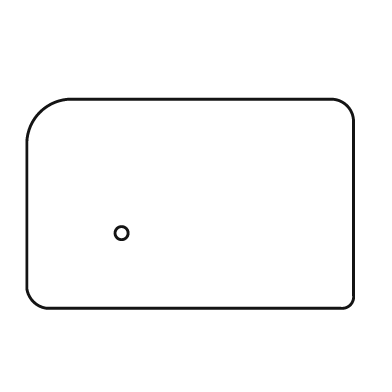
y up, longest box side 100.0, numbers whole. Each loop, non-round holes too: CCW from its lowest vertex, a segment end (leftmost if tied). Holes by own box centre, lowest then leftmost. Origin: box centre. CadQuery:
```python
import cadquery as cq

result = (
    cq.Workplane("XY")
    .moveTo(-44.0, -32.0)
    .lineTo(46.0, -32.0)
    .threePointArc((49.0, -31.0), (50.0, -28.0))
    .lineTo(50.0, 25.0)
    .threePointArc((48.0, 30.0), (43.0, 32.0))
    .lineTo(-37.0, 32.0)
    .threePointArc((-46.0, 28.0), (-50.0, 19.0))
    .lineTo(-50.0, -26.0)
    .threePointArc((-48.0, -30.0), (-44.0, -32.0))
    .close()
    .moveTo(-21.0, -9.0)
    .circle(2.0)
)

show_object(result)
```